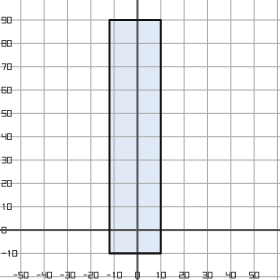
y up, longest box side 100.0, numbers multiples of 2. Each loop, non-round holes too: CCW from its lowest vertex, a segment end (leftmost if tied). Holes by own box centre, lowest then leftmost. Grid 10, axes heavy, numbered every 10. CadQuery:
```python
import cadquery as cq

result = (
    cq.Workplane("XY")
    .moveTo(-12.0, -10.0)
    .lineTo(10.0, -10.0)
    .lineTo(10.0, 90.0)
    .lineTo(-12.0, 90.0)
    .close()
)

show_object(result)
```